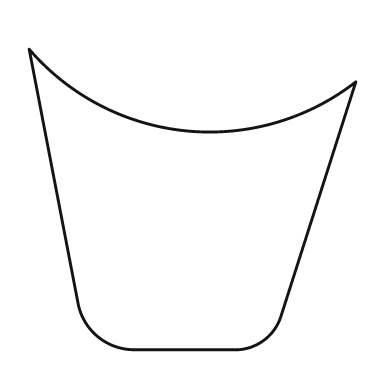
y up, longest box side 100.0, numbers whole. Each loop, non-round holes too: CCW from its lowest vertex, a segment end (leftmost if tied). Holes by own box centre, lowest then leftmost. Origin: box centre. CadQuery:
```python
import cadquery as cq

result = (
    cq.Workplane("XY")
    .moveTo(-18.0, -46.0)
    .lineTo(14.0, -46.0)
    .threePointArc((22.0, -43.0), (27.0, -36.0))
    .lineTo(50.0, 36.0)
    .threePointArc((-2.0, 21.0), (-50.0, 46.0))
    .lineTo(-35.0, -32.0)
    .threePointArc((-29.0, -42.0), (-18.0, -46.0))
    .close()
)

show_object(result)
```